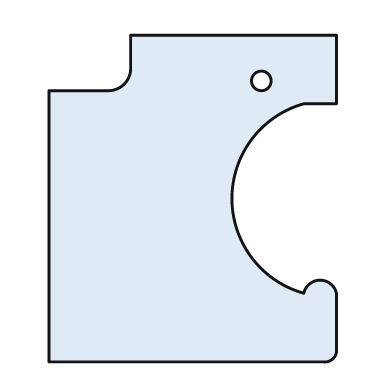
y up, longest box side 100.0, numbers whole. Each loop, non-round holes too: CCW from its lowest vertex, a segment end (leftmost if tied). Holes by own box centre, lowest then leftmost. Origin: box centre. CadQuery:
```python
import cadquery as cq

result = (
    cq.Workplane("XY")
    .moveTo(-44.0, -50.0)
    .lineTo(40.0, -50.0)
    .threePointArc((43.0, -49.0), (44.0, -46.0))
    .lineTo(44.0, -29.0)
    .threePointArc((39.0, -25.0), (34.0, -29.0))
    .threePointArc((12.0, 0.0), (34.0, 29.0))
    .lineTo(44.0, 29.0)
    .lineTo(44.0, 50.0)
    .lineTo(-19.0, 50.0)
    .lineTo(-19.0, 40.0)
    .threePointArc((-21.0, 35.0), (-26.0, 33.0))
    .lineTo(-44.0, 33.0)
    .close()
    .moveTo(21.0, 36.0)
    .circle(3.0)
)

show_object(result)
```